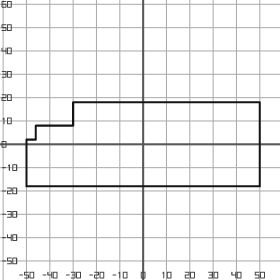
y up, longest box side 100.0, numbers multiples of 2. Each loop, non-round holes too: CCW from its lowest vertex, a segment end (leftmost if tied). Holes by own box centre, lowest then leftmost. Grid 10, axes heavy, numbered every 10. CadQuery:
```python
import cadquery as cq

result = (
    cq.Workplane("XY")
    .moveTo(-50.0, -18.0)
    .lineTo(50.0, -18.0)
    .lineTo(50.0, 18.0)
    .lineTo(-30.0, 18.0)
    .lineTo(-30.0, 8.0)
    .lineTo(-46.0, 8.0)
    .lineTo(-46.0, 2.0)
    .lineTo(-50.0, 2.0)
    .close()
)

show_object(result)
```